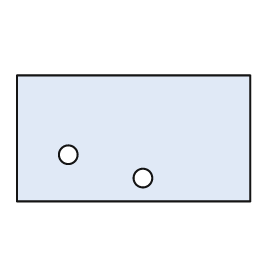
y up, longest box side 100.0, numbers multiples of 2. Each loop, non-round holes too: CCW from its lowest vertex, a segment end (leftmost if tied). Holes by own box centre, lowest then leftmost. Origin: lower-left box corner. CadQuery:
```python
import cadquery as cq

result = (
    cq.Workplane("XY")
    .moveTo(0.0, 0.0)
    .lineTo(100.0, 0.0)
    .lineTo(100.0, 54.0)
    .lineTo(0.0, 54.0)
    .close()
    .moveTo(54.0, 10.0)
    .circle(4.0)
    .moveTo(22.0, 20.0)
    .circle(4.0)
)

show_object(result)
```